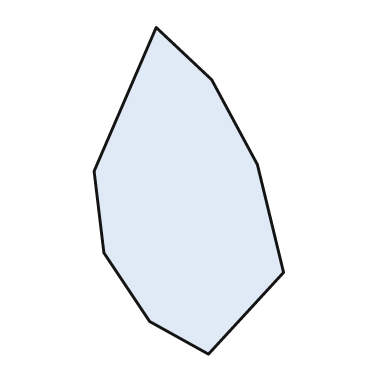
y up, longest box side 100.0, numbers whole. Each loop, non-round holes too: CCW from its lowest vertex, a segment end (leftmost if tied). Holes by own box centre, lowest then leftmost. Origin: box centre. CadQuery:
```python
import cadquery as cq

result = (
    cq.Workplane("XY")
    .moveTo(6.0, -50.0)
    .lineTo(29.0, -25.0)
    .lineTo(21.0, 8.0)
    .lineTo(7.0, 34.0)
    .lineTo(-10.0, 50.0)
    .lineTo(-29.0, 6.0)
    .lineTo(-26.0, -19.0)
    .lineTo(-12.0, -40.0)
    .close()
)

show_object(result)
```